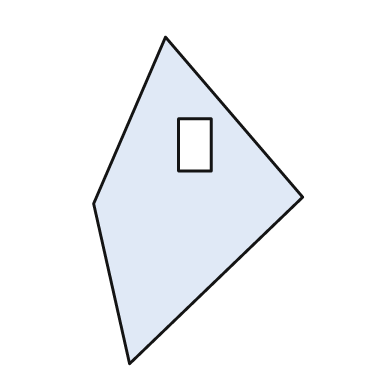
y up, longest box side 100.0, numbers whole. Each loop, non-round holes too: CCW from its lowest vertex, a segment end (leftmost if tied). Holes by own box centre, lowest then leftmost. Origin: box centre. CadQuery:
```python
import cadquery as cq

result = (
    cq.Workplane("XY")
    .moveTo(-21.0, -50.0)
    .lineTo(32.0, 1.0)
    .lineTo(-10.0, 50.0)
    .lineTo(-32.0, -1.0)
    .close()
    .moveTo(-6.0, 9.0)
    .lineTo(4.0, 9.0)
    .lineTo(4.0, 25.0)
    .lineTo(-6.0, 25.0)
    .close()
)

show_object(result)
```